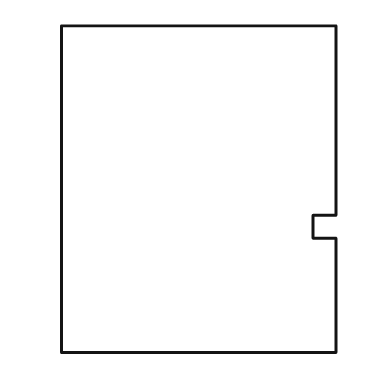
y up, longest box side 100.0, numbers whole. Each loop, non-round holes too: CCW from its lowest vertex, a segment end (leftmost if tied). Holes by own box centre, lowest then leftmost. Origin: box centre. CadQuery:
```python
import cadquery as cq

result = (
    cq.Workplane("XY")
    .moveTo(-42.0, -50.0)
    .lineTo(42.0, -50.0)
    .lineTo(42.0, -15.0)
    .lineTo(35.0, -15.0)
    .lineTo(35.0, -8.0)
    .lineTo(42.0, -8.0)
    .lineTo(42.0, 50.0)
    .lineTo(-42.0, 50.0)
    .close()
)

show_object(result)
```